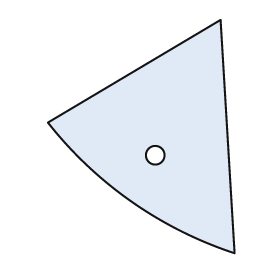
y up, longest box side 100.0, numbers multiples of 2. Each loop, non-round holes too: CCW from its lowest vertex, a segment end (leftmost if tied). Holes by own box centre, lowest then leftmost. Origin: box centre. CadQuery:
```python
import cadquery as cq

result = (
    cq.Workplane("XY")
    .moveTo(40.0, -50.0)
    .lineTo(34.0, 50.0)
    .lineTo(-40.0, 6.0)
    .threePointArc((-4.0, -28.0), (40.0, -50.0))
    .close()
    .moveTo(6.0, -8.0)
    .circle(4.0)
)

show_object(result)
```